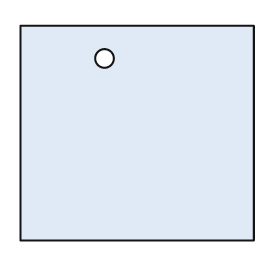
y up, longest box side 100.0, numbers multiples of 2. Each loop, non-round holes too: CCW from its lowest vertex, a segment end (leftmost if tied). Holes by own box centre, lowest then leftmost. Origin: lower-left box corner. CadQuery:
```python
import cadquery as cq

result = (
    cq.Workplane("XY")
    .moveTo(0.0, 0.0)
    .lineTo(100.0, 0.0)
    .lineTo(100.0, 92.0)
    .lineTo(0.0, 92.0)
    .close()
    .moveTo(36.0, 78.0)
    .circle(4.0)
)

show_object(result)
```